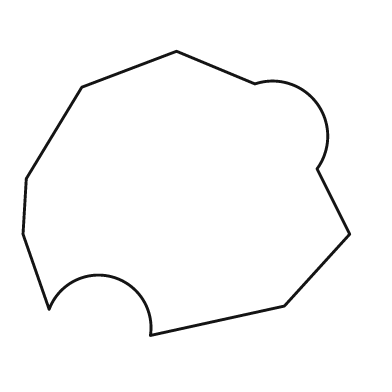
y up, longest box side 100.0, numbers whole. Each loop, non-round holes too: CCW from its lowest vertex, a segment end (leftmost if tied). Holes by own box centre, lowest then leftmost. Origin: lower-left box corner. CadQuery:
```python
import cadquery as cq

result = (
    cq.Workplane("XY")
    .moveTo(39.0, 0.0)
    .lineTo(80.0, 9.0)
    .lineTo(100.0, 31.0)
    .lineTo(90.0, 51.0)
    .threePointArc((90.0, 71.0), (71.0, 77.0))
    .lineTo(47.0, 87.0)
    .lineTo(18.0, 76.0)
    .lineTo(1.0, 48.0)
    .lineTo(0.0, 31.0)
    .lineTo(8.0, 8.0)
    .threePointArc((27.0, 18.0), (39.0, 0.0))
    .close()
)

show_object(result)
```